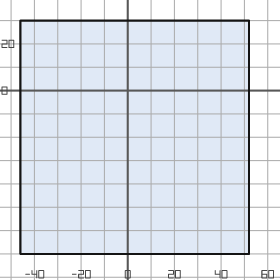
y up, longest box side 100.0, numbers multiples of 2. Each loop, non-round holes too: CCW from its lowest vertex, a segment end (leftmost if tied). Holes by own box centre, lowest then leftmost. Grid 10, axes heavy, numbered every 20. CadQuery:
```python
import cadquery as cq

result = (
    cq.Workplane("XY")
    .moveTo(-46.0, -70.0)
    .lineTo(52.0, -70.0)
    .lineTo(52.0, 30.0)
    .lineTo(-46.0, 30.0)
    .close()
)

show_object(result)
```